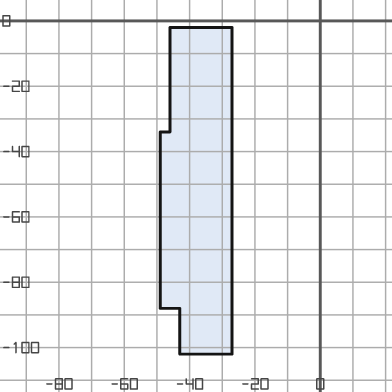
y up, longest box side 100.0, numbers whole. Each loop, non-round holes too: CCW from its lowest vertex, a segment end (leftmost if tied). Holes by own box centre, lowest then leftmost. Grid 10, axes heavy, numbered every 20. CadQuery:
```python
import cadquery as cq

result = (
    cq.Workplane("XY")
    .moveTo(-43.0, -102.0)
    .lineTo(-27.0, -102.0)
    .lineTo(-27.0, -2.0)
    .lineTo(-46.0, -2.0)
    .lineTo(-46.0, -34.0)
    .lineTo(-49.0, -34.0)
    .lineTo(-49.0, -88.0)
    .lineTo(-43.0, -88.0)
    .close()
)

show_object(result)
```